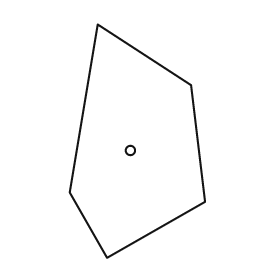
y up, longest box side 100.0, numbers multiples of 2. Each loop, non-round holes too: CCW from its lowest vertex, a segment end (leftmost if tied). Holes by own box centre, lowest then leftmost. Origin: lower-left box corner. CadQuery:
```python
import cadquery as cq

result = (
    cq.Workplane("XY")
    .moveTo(16.0, 0.0)
    .lineTo(58.0, 24.0)
    .lineTo(52.0, 74.0)
    .lineTo(12.0, 100.0)
    .lineTo(0.0, 28.0)
    .close()
    .moveTo(26.0, 46.0)
    .circle(2.0)
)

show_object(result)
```